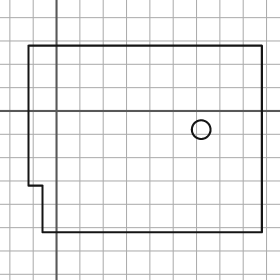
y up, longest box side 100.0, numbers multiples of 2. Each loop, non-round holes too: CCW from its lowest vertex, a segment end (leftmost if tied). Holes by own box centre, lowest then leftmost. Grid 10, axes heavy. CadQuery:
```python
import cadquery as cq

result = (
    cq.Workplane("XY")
    .moveTo(-6.0, -52.0)
    .lineTo(88.0, -52.0)
    .lineTo(88.0, 28.0)
    .lineTo(-12.0, 28.0)
    .lineTo(-12.0, -32.0)
    .lineTo(-6.0, -32.0)
    .close()
    .moveTo(62.0, -8.0)
    .circle(4.0)
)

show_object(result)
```